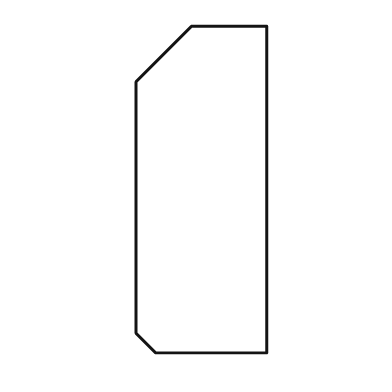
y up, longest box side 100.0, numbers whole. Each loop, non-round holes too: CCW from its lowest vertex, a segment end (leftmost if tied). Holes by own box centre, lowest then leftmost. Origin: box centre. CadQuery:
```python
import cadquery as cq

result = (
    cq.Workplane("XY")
    .moveTo(-14.0, -50.0)
    .lineTo(20.0, -50.0)
    .lineTo(20.0, 50.0)
    .lineTo(-3.0, 50.0)
    .lineTo(-20.0, 33.0)
    .lineTo(-20.0, -44.0)
    .close()
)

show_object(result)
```